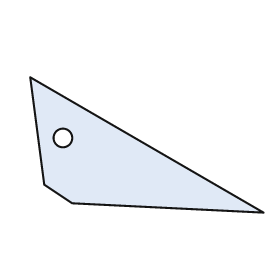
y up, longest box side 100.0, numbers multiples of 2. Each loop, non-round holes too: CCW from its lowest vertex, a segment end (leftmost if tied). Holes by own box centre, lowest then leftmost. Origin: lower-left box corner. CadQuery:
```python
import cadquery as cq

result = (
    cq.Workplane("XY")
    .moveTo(100.0, 0.0)
    .lineTo(0.0, 58.0)
    .lineTo(6.0, 12.0)
    .lineTo(18.0, 4.0)
    .close()
    .moveTo(14.0, 32.0)
    .circle(4.0)
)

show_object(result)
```